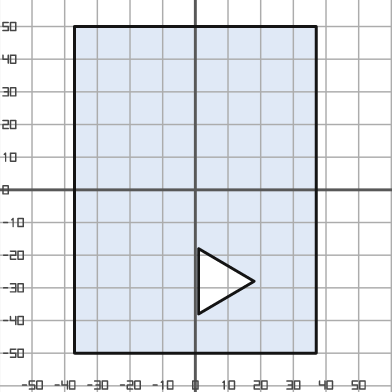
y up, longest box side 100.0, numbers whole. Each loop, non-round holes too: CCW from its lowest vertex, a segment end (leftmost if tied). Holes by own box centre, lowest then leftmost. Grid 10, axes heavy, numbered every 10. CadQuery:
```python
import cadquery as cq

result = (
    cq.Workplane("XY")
    .moveTo(-37.0, -50.0)
    .lineTo(37.0, -50.0)
    .lineTo(37.0, 50.0)
    .lineTo(-37.0, 50.0)
    .close()
    .moveTo(1.0, -38.0)
    .lineTo(18.0, -28.0)
    .lineTo(1.0, -18.0)
    .close()
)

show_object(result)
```